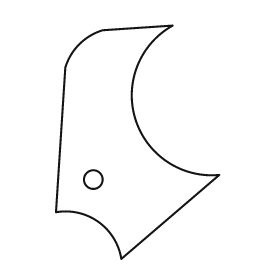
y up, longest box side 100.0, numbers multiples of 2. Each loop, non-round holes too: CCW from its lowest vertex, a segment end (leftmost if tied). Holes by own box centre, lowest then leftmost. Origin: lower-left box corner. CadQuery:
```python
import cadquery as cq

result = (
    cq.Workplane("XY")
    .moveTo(28.0, 0.0)
    .lineTo(70.0, 36.0)
    .threePointArc((34.0, 60.0), (50.0, 100.0))
    .lineTo(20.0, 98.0)
    .threePointArc((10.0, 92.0), (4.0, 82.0))
    .lineTo(0.0, 20.0)
    .threePointArc((18.0, 16.0), (28.0, 0.0))
    .close()
    .moveTo(16.0, 34.0)
    .circle(4.0)
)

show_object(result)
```